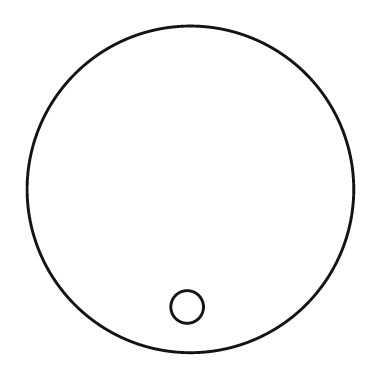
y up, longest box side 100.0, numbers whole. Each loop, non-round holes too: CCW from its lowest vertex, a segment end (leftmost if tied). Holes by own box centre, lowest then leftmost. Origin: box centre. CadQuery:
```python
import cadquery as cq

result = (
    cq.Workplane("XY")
    .moveTo(0.0, 0.0)
    .circle(50.0)
    .moveTo(-1.0, -36.0)
    .circle(5.0)
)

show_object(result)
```